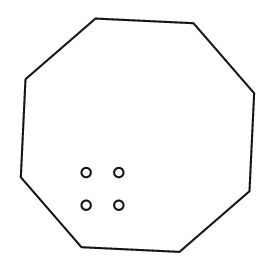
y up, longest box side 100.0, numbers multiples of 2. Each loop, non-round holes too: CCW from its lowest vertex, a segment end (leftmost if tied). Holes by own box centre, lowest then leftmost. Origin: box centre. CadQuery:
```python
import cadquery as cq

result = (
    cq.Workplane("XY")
    .moveTo(18.0, -50.0)
    .lineTo(48.0, -24.0)
    .lineTo(50.0, 18.0)
    .lineTo(24.0, 48.0)
    .lineTo(-18.0, 50.0)
    .lineTo(-48.0, 24.0)
    .lineTo(-50.0, -18.0)
    .lineTo(-24.0, -48.0)
    .close()
    .moveTo(-22.0, -30.0)
    .circle(2.0)
    .moveTo(-8.0, -30.0)
    .circle(2.0)
    .moveTo(-22.0, -16.0)
    .circle(2.0)
    .moveTo(-8.0, -16.0)
    .circle(2.0)
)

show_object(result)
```